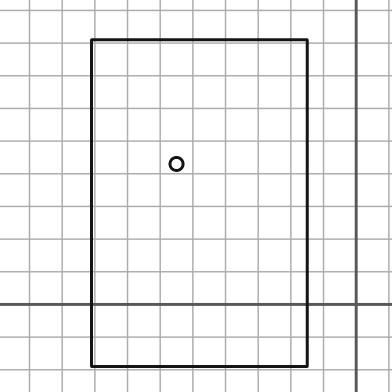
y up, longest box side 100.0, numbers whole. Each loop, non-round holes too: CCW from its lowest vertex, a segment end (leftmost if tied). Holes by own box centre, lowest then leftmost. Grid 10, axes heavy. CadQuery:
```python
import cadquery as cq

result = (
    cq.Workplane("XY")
    .moveTo(-81.0, -19.0)
    .lineTo(-15.0, -19.0)
    .lineTo(-15.0, 81.0)
    .lineTo(-81.0, 81.0)
    .close()
    .moveTo(-55.0, 43.0)
    .circle(2.0)
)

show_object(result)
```